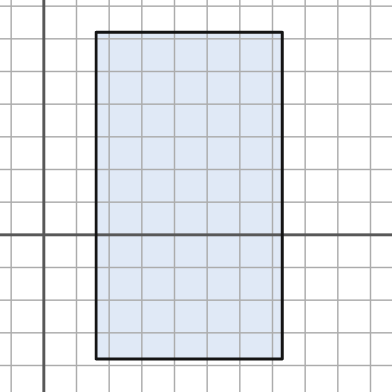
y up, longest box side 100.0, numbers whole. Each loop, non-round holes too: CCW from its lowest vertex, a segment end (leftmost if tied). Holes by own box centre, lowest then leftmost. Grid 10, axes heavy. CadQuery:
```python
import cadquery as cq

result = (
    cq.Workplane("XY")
    .moveTo(16.0, -38.0)
    .lineTo(73.0, -38.0)
    .lineTo(73.0, 62.0)
    .lineTo(16.0, 62.0)
    .close()
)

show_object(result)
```